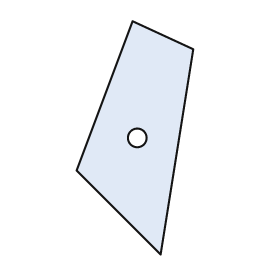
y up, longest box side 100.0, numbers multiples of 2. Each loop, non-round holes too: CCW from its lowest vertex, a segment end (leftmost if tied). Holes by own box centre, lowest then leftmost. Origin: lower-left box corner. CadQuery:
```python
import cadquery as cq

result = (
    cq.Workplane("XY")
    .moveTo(36.0, 0.0)
    .lineTo(50.0, 88.0)
    .lineTo(24.0, 100.0)
    .lineTo(0.0, 36.0)
    .close()
    .moveTo(26.0, 50.0)
    .circle(4.0)
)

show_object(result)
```